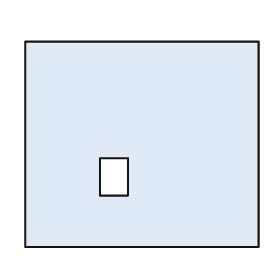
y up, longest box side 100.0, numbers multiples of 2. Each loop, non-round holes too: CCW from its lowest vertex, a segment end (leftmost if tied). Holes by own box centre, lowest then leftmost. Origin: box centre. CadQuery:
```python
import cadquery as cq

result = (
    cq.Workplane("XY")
    .moveTo(-50.0, -44.0)
    .lineTo(50.0, -44.0)
    .lineTo(50.0, 44.0)
    .lineTo(-50.0, 44.0)
    .close()
    .moveTo(-18.0, -22.0)
    .lineTo(-6.0, -22.0)
    .lineTo(-6.0, -6.0)
    .lineTo(-18.0, -6.0)
    .close()
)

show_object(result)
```